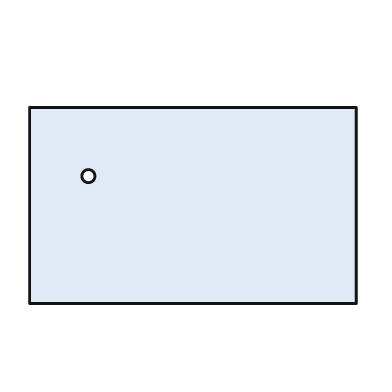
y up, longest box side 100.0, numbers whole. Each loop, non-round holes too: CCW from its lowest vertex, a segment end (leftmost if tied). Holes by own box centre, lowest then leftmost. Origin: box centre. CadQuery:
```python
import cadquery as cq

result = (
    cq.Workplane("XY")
    .moveTo(-50.0, -30.0)
    .lineTo(50.0, -30.0)
    .lineTo(50.0, 30.0)
    .lineTo(-50.0, 30.0)
    .close()
    .moveTo(-32.0, 9.0)
    .circle(2.0)
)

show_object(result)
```